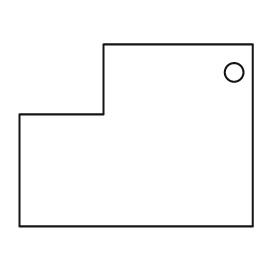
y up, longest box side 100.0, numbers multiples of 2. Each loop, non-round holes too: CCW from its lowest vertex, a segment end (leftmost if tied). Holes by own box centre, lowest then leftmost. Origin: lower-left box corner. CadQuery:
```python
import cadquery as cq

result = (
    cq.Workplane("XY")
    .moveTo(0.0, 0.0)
    .lineTo(100.0, 0.0)
    .lineTo(100.0, 78.0)
    .lineTo(36.0, 78.0)
    .lineTo(36.0, 48.0)
    .lineTo(0.0, 48.0)
    .close()
    .moveTo(92.0, 66.0)
    .circle(4.0)
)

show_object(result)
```